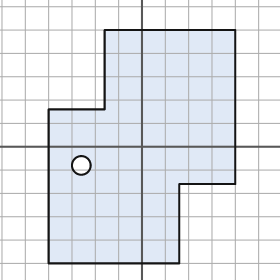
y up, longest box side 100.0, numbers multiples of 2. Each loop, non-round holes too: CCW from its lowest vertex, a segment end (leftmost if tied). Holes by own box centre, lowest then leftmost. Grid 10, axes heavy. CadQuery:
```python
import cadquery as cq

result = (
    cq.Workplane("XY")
    .moveTo(-40.0, -50.0)
    .lineTo(16.0, -50.0)
    .lineTo(16.0, -16.0)
    .lineTo(40.0, -16.0)
    .lineTo(40.0, 50.0)
    .lineTo(-16.0, 50.0)
    .lineTo(-16.0, 16.0)
    .lineTo(-40.0, 16.0)
    .close()
    .moveTo(-26.0, -8.0)
    .circle(4.0)
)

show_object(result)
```